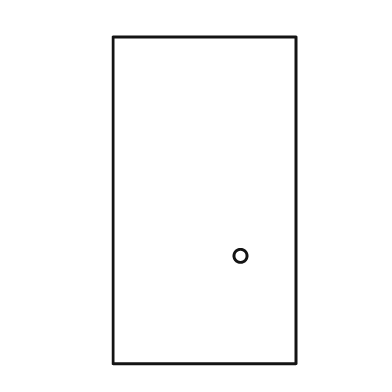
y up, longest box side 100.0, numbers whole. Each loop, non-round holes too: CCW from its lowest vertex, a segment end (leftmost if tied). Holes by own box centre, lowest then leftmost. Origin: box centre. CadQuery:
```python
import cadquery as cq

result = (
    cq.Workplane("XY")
    .moveTo(-28.0, -50.0)
    .lineTo(28.0, -50.0)
    .lineTo(28.0, 50.0)
    .lineTo(-28.0, 50.0)
    .close()
    .moveTo(11.0, -17.0)
    .circle(2.0)
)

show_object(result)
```